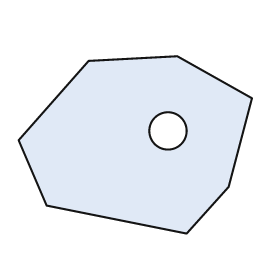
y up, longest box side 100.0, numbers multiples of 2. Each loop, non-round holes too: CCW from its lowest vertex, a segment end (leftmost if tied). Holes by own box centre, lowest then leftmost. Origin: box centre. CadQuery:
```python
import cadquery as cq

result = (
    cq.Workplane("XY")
    .moveTo(22.0, -38.0)
    .lineTo(40.0, -18.0)
    .lineTo(50.0, 20.0)
    .lineTo(18.0, 38.0)
    .lineTo(-20.0, 36.0)
    .lineTo(-50.0, 2.0)
    .lineTo(-38.0, -26.0)
    .close()
    .moveTo(14.0, 6.0)
    .circle(8.0)
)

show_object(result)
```